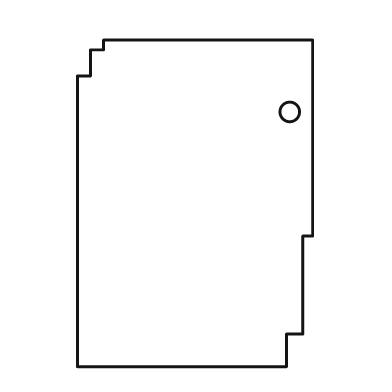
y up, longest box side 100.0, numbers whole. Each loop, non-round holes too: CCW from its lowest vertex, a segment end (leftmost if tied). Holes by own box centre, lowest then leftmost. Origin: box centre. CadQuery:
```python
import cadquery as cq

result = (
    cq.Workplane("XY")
    .moveTo(-36.0, -50.0)
    .lineTo(28.0, -50.0)
    .lineTo(28.0, -40.0)
    .lineTo(33.0, -40.0)
    .lineTo(33.0, -10.0)
    .lineTo(36.0, -10.0)
    .lineTo(36.0, 50.0)
    .lineTo(-28.0, 50.0)
    .lineTo(-28.0, 47.0)
    .lineTo(-32.0, 47.0)
    .lineTo(-32.0, 39.0)
    .lineTo(-36.0, 39.0)
    .close()
    .moveTo(29.0, 28.0)
    .circle(3.0)
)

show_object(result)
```